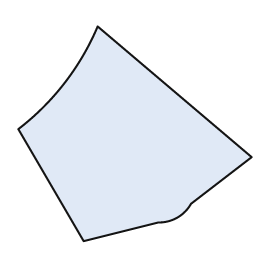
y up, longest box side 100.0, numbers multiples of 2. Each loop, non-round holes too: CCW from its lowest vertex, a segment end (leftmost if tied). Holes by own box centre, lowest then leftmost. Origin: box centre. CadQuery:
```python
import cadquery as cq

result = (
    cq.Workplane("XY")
    .moveTo(-22.0, -46.0)
    .lineTo(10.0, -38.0)
    .threePointArc((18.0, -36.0), (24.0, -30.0))
    .lineTo(50.0, -10.0)
    .lineTo(-16.0, 46.0)
    .threePointArc((-30.0, 22.0), (-50.0, 2.0))
    .close()
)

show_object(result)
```